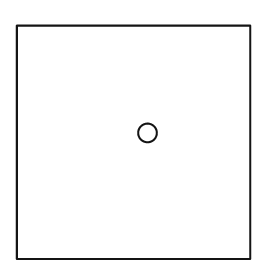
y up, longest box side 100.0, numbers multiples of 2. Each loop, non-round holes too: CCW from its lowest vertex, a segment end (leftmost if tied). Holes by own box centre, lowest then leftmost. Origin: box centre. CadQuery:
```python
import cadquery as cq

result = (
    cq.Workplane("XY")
    .moveTo(-50.0, -50.0)
    .lineTo(50.0, -50.0)
    .lineTo(50.0, 50.0)
    .lineTo(-50.0, 50.0)
    .close()
    .moveTo(6.0, 4.0)
    .circle(4.0)
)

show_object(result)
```